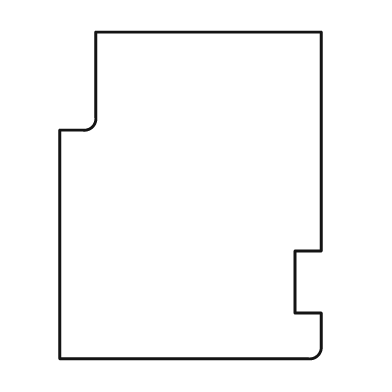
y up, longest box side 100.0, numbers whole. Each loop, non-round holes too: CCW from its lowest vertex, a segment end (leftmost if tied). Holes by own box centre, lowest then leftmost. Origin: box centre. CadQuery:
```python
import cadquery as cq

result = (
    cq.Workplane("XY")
    .moveTo(-40.0, -50.0)
    .lineTo(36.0, -50.0)
    .threePointArc((39.0, -49.0), (40.0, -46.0))
    .lineTo(40.0, -36.0)
    .lineTo(32.0, -36.0)
    .lineTo(32.0, -17.0)
    .lineTo(40.0, -17.0)
    .lineTo(40.0, 50.0)
    .lineTo(-29.0, 50.0)
    .lineTo(-29.0, 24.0)
    .threePointArc((-30.0, 21.0), (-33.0, 20.0))
    .lineTo(-40.0, 20.0)
    .close()
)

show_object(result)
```